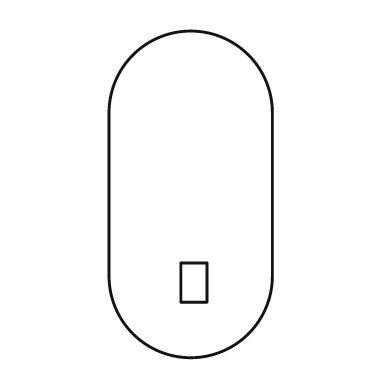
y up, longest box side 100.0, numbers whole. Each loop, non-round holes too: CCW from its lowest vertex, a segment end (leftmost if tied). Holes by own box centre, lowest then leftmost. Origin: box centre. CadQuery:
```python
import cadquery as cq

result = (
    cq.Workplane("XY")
    .moveTo(-25.0, -25.0)
    .threePointArc((0.0, -50.0), (25.0, -25.0))
    .lineTo(25.0, 25.0)
    .threePointArc((0.0, 50.0), (-25.0, 25.0))
    .close()
    .moveTo(-3.0, -33.0)
    .lineTo(5.0, -33.0)
    .lineTo(5.0, -21.0)
    .lineTo(-3.0, -21.0)
    .close()
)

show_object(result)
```